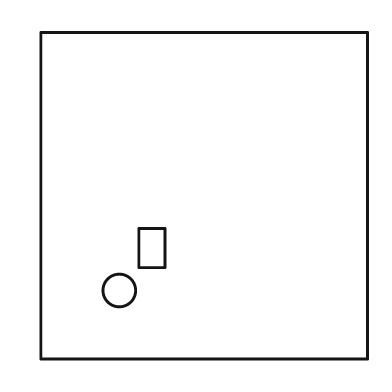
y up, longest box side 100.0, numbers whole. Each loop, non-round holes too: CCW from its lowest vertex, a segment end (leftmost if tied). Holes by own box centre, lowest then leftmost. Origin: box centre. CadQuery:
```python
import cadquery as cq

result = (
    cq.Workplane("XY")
    .moveTo(-50.0, -50.0)
    .lineTo(50.0, -50.0)
    .lineTo(50.0, 50.0)
    .lineTo(-50.0, 50.0)
    .close()
    .moveTo(-26.0, -29.0)
    .circle(5.0)
    .moveTo(-20.0, -22.0)
    .lineTo(-12.0, -22.0)
    .lineTo(-12.0, -10.0)
    .lineTo(-20.0, -10.0)
    .close()
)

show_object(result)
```